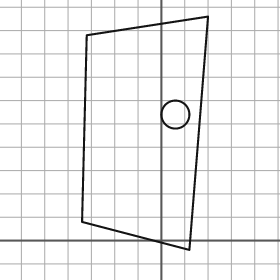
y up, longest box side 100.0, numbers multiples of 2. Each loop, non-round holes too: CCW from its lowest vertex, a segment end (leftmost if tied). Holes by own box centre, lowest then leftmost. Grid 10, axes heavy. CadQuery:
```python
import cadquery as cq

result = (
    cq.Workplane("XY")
    .moveTo(12.0, -4.0)
    .lineTo(20.0, 96.0)
    .lineTo(-32.0, 88.0)
    .lineTo(-34.0, 8.0)
    .close()
    .moveTo(6.0, 54.0)
    .circle(6.0)
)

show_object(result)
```